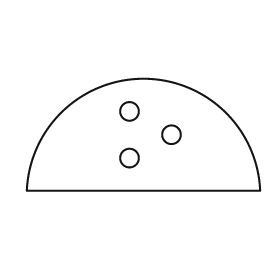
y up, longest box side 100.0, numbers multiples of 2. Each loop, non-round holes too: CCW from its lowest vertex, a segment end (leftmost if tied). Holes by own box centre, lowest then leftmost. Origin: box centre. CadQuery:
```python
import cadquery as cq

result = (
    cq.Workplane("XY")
    .moveTo(-50.0, -24.0)
    .lineTo(50.0, -24.0)
    .threePointArc((0.0, 24.0), (-50.0, -24.0))
    .close()
    .moveTo(-6.0, -10.0)
    .circle(4.0)
    .moveTo(12.0, 0.0)
    .circle(4.0)
    .moveTo(-6.0, 10.0)
    .circle(4.0)
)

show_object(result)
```